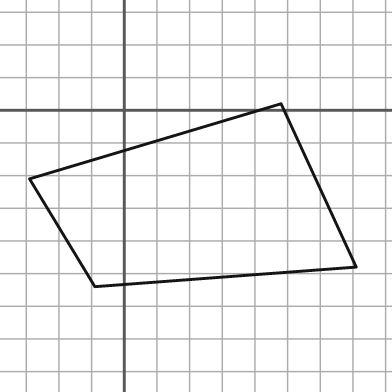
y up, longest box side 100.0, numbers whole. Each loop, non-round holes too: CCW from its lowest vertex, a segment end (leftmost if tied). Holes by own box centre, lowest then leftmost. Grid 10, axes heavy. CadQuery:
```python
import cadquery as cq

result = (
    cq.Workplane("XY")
    .moveTo(-9.0, -54.0)
    .lineTo(71.0, -48.0)
    .lineTo(48.0, 2.0)
    .lineTo(-29.0, -21.0)
    .close()
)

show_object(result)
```